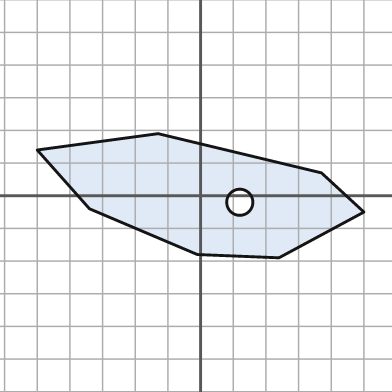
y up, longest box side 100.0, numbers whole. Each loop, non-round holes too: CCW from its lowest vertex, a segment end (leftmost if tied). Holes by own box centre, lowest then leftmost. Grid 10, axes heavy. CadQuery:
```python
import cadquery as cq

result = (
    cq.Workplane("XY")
    .moveTo(24.0, -19.0)
    .lineTo(50.0, -5.0)
    .lineTo(37.0, 7.0)
    .lineTo(-13.0, 19.0)
    .lineTo(-50.0, 14.0)
    .lineTo(-34.0, -4.0)
    .lineTo(-1.0, -18.0)
    .close()
    .moveTo(12.0, -2.0)
    .circle(4.0)
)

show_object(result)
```